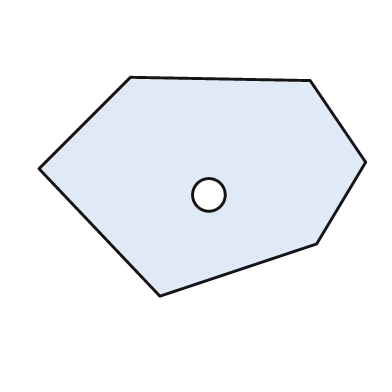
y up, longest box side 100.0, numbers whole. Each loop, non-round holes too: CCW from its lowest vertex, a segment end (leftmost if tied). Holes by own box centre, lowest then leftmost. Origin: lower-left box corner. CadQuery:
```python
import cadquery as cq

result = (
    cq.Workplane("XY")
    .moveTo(37.0, 0.0)
    .lineTo(85.0, 16.0)
    .lineTo(100.0, 41.0)
    .lineTo(83.0, 66.0)
    .lineTo(28.0, 67.0)
    .lineTo(0.0, 39.0)
    .close()
    .moveTo(52.0, 31.0)
    .circle(5.0)
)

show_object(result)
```